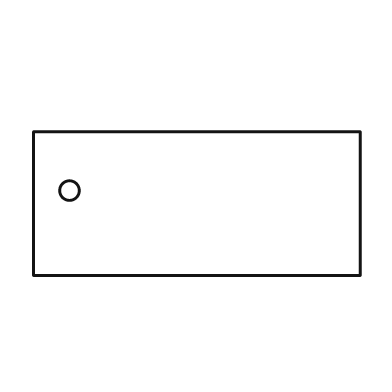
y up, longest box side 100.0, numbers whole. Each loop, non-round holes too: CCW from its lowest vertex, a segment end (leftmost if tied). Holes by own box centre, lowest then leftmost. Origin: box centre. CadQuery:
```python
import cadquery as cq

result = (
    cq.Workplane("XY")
    .moveTo(-50.0, -22.0)
    .lineTo(50.0, -22.0)
    .lineTo(50.0, 22.0)
    .lineTo(-50.0, 22.0)
    .close()
    .moveTo(-39.0, 4.0)
    .circle(3.0)
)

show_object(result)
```